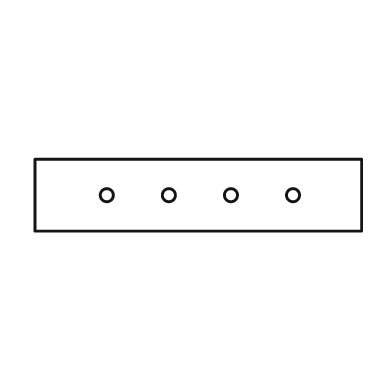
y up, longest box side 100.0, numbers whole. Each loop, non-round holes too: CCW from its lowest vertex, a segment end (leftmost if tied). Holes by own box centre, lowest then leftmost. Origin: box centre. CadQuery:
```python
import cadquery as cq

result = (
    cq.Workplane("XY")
    .moveTo(-50.0, -11.0)
    .lineTo(50.0, -11.0)
    .lineTo(50.0, 11.0)
    .lineTo(-50.0, 11.0)
    .close()
    .moveTo(-28.0, 0.0)
    .circle(2.0)
    .moveTo(-9.0, 0.0)
    .circle(2.0)
    .moveTo(10.0, 0.0)
    .circle(2.0)
    .moveTo(29.0, 0.0)
    .circle(2.0)
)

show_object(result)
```